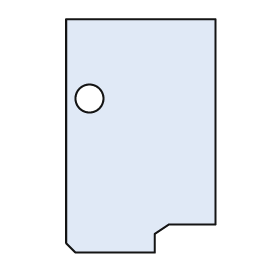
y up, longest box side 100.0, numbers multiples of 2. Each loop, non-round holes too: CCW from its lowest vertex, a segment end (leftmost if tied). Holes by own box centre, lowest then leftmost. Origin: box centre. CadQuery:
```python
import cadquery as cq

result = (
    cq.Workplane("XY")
    .moveTo(-28.0, -50.0)
    .lineTo(6.0, -50.0)
    .lineTo(6.0, -42.0)
    .lineTo(12.0, -38.0)
    .lineTo(32.0, -38.0)
    .lineTo(32.0, 50.0)
    .lineTo(-32.0, 50.0)
    .lineTo(-32.0, -46.0)
    .close()
    .moveTo(-22.0, 16.0)
    .circle(6.0)
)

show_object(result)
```